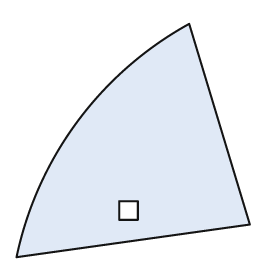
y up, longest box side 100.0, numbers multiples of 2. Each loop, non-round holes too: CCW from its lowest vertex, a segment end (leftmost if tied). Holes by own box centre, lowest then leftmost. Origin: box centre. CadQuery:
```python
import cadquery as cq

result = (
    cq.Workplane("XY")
    .moveTo(-50.0, -50.0)
    .lineTo(50.0, -36.0)
    .lineTo(24.0, 50.0)
    .threePointArc((-24.0, 8.0), (-50.0, -50.0))
    .close()
    .moveTo(-6.0, -34.0)
    .lineTo(2.0, -34.0)
    .lineTo(2.0, -26.0)
    .lineTo(-6.0, -26.0)
    .close()
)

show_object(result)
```